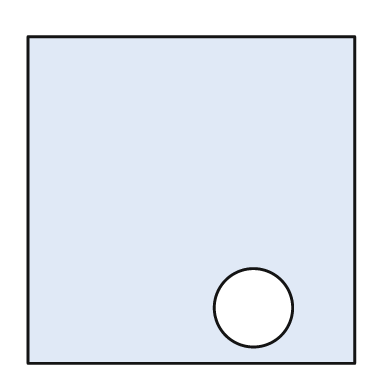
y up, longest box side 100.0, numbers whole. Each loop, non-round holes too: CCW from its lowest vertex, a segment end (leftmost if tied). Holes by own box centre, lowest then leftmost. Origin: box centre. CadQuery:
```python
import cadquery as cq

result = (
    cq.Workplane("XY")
    .moveTo(-50.0, -50.0)
    .lineTo(50.0, -50.0)
    .lineTo(50.0, 50.0)
    .lineTo(-50.0, 50.0)
    .close()
    .moveTo(19.0, -33.0)
    .circle(12.0)
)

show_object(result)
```